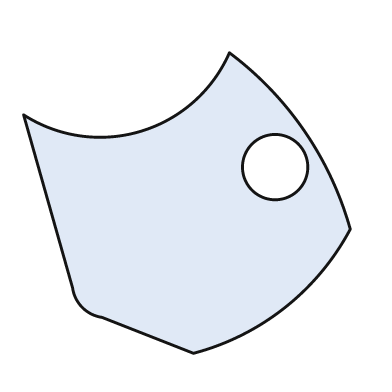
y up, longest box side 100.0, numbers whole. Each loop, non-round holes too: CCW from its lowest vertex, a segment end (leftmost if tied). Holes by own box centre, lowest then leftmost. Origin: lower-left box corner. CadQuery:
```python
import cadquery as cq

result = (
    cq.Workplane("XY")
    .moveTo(52.0, 0.0)
    .threePointArc((80.0, 14.0), (100.0, 38.0))
    .threePointArc((86.0, 68.0), (63.0, 92.0))
    .threePointArc((36.0, 68.0), (0.0, 73.0))
    .lineTo(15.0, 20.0)
    .threePointArc((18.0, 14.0), (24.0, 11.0))
    .close()
    .moveTo(77.0, 57.0)
    .circle(10.0)
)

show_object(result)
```